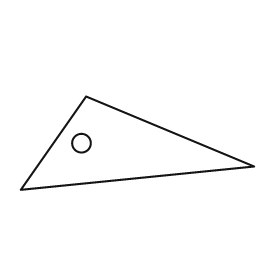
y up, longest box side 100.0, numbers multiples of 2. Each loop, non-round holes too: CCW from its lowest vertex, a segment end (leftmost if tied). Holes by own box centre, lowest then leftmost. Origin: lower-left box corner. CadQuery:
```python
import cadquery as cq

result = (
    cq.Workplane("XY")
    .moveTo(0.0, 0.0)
    .lineTo(100.0, 10.0)
    .lineTo(28.0, 40.0)
    .close()
    .moveTo(26.0, 20.0)
    .circle(4.0)
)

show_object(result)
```